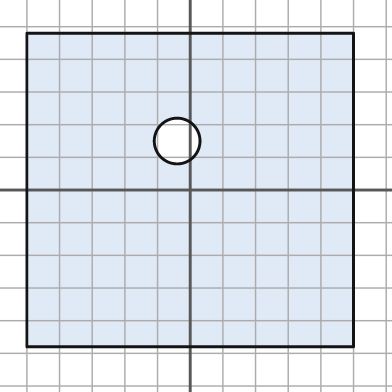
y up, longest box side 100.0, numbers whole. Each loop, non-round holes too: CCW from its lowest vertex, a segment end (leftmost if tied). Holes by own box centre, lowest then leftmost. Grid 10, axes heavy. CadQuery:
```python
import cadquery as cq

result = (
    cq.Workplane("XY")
    .moveTo(-50.0, -48.0)
    .lineTo(50.0, -48.0)
    .lineTo(50.0, 48.0)
    .lineTo(-50.0, 48.0)
    .close()
    .moveTo(-4.0, 15.0)
    .circle(7.0)
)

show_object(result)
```